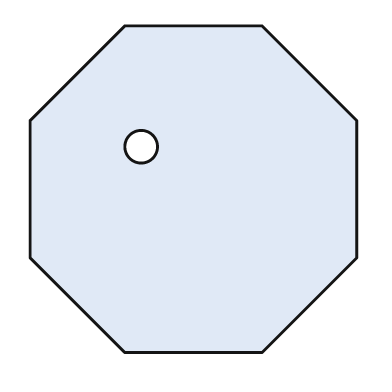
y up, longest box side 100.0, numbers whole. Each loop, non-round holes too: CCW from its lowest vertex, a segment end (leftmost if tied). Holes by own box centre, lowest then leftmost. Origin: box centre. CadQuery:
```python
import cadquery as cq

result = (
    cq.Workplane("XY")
    .moveTo(-21.0, -50.0)
    .lineTo(21.0, -50.0)
    .lineTo(50.0, -21.0)
    .lineTo(50.0, 21.0)
    .lineTo(21.0, 50.0)
    .lineTo(-21.0, 50.0)
    .lineTo(-50.0, 21.0)
    .lineTo(-50.0, -21.0)
    .close()
    .moveTo(-16.0, 13.0)
    .circle(5.0)
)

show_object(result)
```